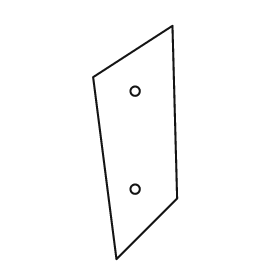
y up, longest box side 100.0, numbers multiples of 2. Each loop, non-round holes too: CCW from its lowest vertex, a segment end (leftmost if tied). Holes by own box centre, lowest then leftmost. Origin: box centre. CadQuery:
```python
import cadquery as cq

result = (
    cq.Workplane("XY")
    .moveTo(-8.0, -50.0)
    .lineTo(18.0, -24.0)
    .lineTo(16.0, 50.0)
    .lineTo(-18.0, 28.0)
    .close()
    .moveTo(0.0, -20.0)
    .circle(2.0)
    .moveTo(0.0, 22.0)
    .circle(2.0)
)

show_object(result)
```